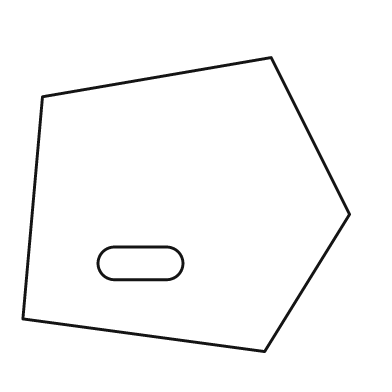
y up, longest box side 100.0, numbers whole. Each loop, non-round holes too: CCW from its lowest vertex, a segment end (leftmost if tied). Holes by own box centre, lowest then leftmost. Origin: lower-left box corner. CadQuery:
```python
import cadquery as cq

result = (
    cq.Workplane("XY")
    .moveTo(74.0, 0.0)
    .lineTo(100.0, 42.0)
    .lineTo(76.0, 90.0)
    .lineTo(6.0, 78.0)
    .lineTo(0.0, 10.0)
    .close()
    .moveTo(28.0, 22.0)
    .lineTo(44.0, 22.0)
    .threePointArc((49.0, 27.0), (44.0, 32.0))
    .lineTo(28.0, 32.0)
    .threePointArc((23.0, 27.0), (28.0, 22.0))
    .close()
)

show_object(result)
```